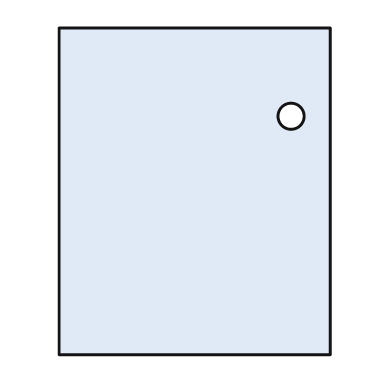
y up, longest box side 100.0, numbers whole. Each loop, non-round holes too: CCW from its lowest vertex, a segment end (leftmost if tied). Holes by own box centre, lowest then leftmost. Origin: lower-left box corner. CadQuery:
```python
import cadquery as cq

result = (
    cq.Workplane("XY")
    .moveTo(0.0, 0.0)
    .lineTo(83.0, 0.0)
    .lineTo(83.0, 100.0)
    .lineTo(0.0, 100.0)
    .close()
    .moveTo(71.0, 73.0)
    .circle(4.0)
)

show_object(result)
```